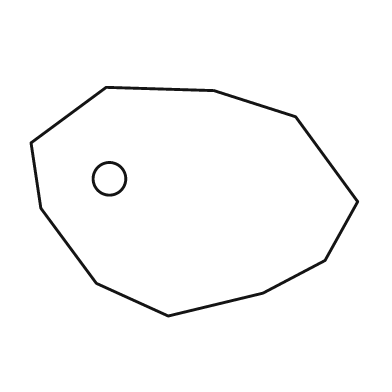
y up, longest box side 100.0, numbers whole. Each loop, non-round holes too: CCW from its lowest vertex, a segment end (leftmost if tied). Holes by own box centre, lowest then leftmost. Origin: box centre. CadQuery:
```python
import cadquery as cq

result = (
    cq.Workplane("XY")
    .moveTo(-8.0, -35.0)
    .lineTo(21.0, -28.0)
    .lineTo(40.0, -18.0)
    .lineTo(50.0, 0.0)
    .lineTo(31.0, 26.0)
    .lineTo(6.0, 34.0)
    .lineTo(-27.0, 35.0)
    .lineTo(-50.0, 18.0)
    .lineTo(-47.0, -2.0)
    .lineTo(-30.0, -25.0)
    .close()
    .moveTo(-26.0, 7.0)
    .circle(5.0)
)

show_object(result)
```